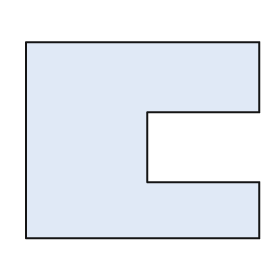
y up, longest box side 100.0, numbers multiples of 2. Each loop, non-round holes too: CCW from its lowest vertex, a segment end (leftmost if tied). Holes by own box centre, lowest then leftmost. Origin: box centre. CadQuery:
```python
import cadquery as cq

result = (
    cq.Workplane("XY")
    .moveTo(-50.0, -42.0)
    .lineTo(50.0, -42.0)
    .lineTo(50.0, -18.0)
    .lineTo(2.0, -18.0)
    .lineTo(2.0, 12.0)
    .lineTo(50.0, 12.0)
    .lineTo(50.0, 42.0)
    .lineTo(-50.0, 42.0)
    .close()
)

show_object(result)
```